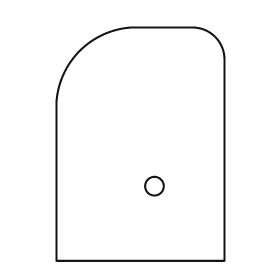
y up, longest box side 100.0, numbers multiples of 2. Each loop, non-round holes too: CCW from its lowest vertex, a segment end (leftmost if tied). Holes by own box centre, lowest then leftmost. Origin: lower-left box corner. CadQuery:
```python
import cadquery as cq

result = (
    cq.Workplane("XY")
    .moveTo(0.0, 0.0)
    .lineTo(72.0, 0.0)
    .lineTo(72.0, 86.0)
    .threePointArc((68.0, 96.0), (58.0, 100.0))
    .lineTo(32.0, 100.0)
    .threePointArc((10.0, 90.0), (0.0, 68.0))
    .close()
    .moveTo(42.0, 32.0)
    .circle(4.0)
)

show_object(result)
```